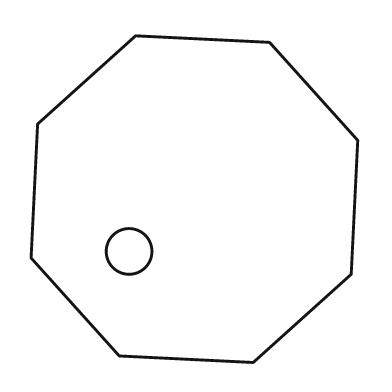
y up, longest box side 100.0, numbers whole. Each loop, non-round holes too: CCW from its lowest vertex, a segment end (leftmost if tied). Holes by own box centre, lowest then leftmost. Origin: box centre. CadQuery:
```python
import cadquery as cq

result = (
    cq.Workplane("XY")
    .moveTo(18.0, -50.0)
    .lineTo(48.0, -23.0)
    .lineTo(50.0, 18.0)
    .lineTo(23.0, 48.0)
    .lineTo(-18.0, 50.0)
    .lineTo(-48.0, 23.0)
    .lineTo(-50.0, -18.0)
    .lineTo(-23.0, -48.0)
    .close()
    .moveTo(-20.0, -16.0)
    .circle(7.0)
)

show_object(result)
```